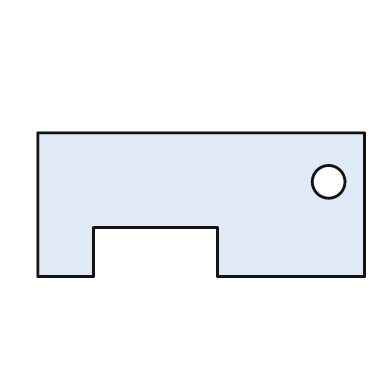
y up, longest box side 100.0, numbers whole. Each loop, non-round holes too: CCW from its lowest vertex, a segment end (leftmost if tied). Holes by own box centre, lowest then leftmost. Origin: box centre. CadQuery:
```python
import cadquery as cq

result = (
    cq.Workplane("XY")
    .moveTo(-50.0, -22.0)
    .lineTo(-33.0, -22.0)
    .lineTo(-33.0, -7.0)
    .lineTo(5.0, -7.0)
    .lineTo(5.0, -22.0)
    .lineTo(50.0, -22.0)
    .lineTo(50.0, 22.0)
    .lineTo(-50.0, 22.0)
    .close()
    .moveTo(39.0, 7.0)
    .circle(5.0)
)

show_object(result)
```